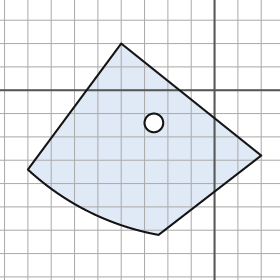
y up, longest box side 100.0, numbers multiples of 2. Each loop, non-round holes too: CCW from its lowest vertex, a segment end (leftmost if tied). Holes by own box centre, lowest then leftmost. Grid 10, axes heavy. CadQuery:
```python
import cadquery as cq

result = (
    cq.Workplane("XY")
    .moveTo(-24.0, -62.0)
    .lineTo(20.0, -28.0)
    .lineTo(-40.0, 20.0)
    .lineTo(-80.0, -34.0)
    .threePointArc((-54.0, -52.0), (-24.0, -62.0))
    .close()
    .moveTo(-26.0, -14.0)
    .circle(4.0)
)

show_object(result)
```